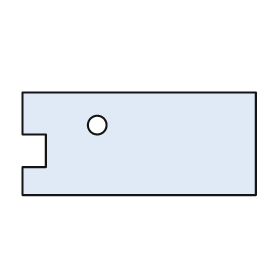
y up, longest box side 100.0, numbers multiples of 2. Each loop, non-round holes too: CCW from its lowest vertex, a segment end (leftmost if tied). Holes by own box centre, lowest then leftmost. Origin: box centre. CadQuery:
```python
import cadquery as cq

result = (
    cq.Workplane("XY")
    .moveTo(-50.0, -22.0)
    .lineTo(50.0, -22.0)
    .lineTo(50.0, 22.0)
    .lineTo(-50.0, 22.0)
    .lineTo(-50.0, 4.0)
    .lineTo(-40.0, 4.0)
    .lineTo(-40.0, -10.0)
    .lineTo(-50.0, -10.0)
    .close()
    .moveTo(-18.0, 8.0)
    .circle(4.0)
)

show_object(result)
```